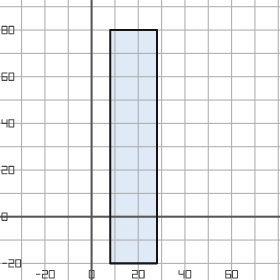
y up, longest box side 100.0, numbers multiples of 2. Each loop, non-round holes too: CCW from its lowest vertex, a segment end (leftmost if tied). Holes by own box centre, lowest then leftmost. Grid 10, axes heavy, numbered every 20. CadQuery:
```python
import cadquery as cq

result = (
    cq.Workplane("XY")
    .moveTo(8.0, -20.0)
    .lineTo(28.0, -20.0)
    .lineTo(28.0, 80.0)
    .lineTo(8.0, 80.0)
    .close()
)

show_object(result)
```